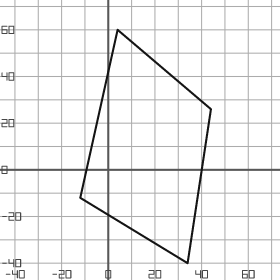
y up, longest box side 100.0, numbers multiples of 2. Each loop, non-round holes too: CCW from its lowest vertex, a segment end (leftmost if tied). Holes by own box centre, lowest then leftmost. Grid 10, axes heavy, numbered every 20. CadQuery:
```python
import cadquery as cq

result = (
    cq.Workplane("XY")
    .moveTo(34.0, -40.0)
    .lineTo(44.0, 26.0)
    .lineTo(4.0, 60.0)
    .lineTo(-12.0, -12.0)
    .close()
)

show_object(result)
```